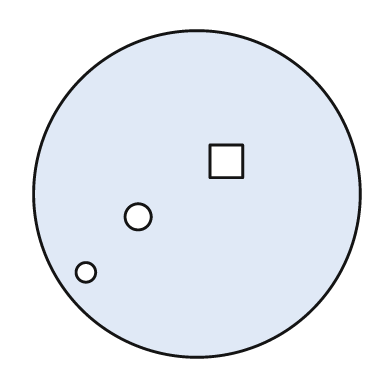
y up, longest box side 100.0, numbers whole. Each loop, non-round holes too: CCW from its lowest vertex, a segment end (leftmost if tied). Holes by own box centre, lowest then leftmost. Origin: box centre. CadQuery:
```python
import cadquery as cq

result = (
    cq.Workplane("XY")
    .moveTo(0.0, 0.0)
    .circle(50.0)
    .moveTo(-34.0, -24.0)
    .circle(3.0)
    .moveTo(-18.0, -7.0)
    .circle(4.0)
    .moveTo(4.0, 5.0)
    .lineTo(14.0, 5.0)
    .lineTo(14.0, 15.0)
    .lineTo(4.0, 15.0)
    .close()
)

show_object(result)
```